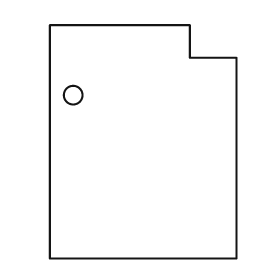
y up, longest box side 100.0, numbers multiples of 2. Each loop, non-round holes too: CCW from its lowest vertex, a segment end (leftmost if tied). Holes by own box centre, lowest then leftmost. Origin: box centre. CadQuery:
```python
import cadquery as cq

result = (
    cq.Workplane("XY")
    .moveTo(-40.0, -50.0)
    .lineTo(40.0, -50.0)
    .lineTo(40.0, 36.0)
    .lineTo(20.0, 36.0)
    .lineTo(20.0, 50.0)
    .lineTo(-40.0, 50.0)
    .close()
    .moveTo(-30.0, 20.0)
    .circle(4.0)
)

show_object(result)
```